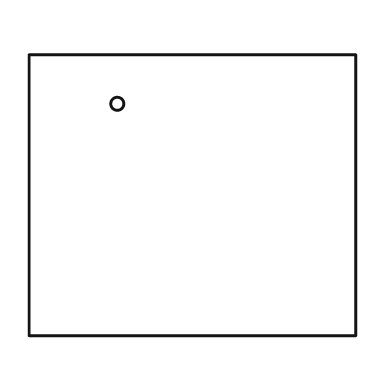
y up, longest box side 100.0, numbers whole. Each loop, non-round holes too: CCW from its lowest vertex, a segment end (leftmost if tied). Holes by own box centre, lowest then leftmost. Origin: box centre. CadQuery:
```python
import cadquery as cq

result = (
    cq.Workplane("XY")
    .moveTo(-50.0, -43.0)
    .lineTo(50.0, -43.0)
    .lineTo(50.0, 43.0)
    .lineTo(-50.0, 43.0)
    .close()
    .moveTo(-23.0, 28.0)
    .circle(2.0)
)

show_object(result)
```